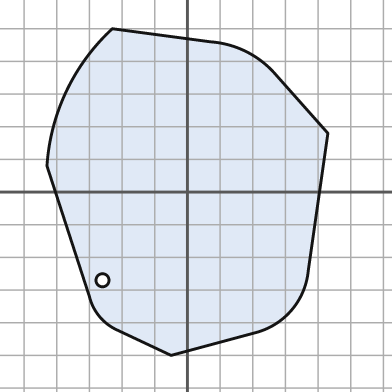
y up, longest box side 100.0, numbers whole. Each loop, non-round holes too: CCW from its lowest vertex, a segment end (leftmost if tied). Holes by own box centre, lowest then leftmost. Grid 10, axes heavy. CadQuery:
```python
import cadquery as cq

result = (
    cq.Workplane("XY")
    .moveTo(-5.0, -50.0)
    .lineTo(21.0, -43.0)
    .threePointArc((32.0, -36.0), (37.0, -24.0))
    .lineTo(43.0, 18.0)
    .lineTo(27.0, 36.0)
    .threePointArc((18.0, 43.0), (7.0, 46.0))
    .lineTo(-23.0, 50.0)
    .threePointArc((-37.0, 31.0), (-43.0, 8.0))
    .lineTo(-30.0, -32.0)
    .threePointArc((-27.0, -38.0), (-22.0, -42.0))
    .close()
    .moveTo(-26.0, -27.0)
    .circle(2.0)
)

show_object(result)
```